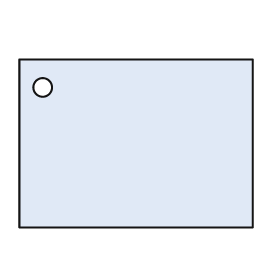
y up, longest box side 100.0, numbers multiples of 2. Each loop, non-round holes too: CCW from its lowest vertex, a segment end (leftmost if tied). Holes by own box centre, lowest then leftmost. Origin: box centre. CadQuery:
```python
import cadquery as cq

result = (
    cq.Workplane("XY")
    .moveTo(-50.0, -36.0)
    .lineTo(50.0, -36.0)
    .lineTo(50.0, 36.0)
    .lineTo(-50.0, 36.0)
    .close()
    .moveTo(-40.0, 24.0)
    .circle(4.0)
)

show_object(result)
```